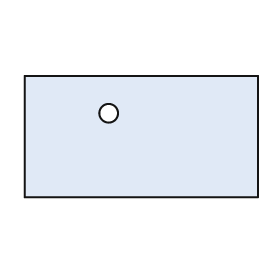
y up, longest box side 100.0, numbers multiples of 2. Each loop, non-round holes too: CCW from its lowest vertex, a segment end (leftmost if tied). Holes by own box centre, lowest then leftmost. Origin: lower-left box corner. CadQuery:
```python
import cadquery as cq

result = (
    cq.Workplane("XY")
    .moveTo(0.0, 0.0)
    .lineTo(100.0, 0.0)
    .lineTo(100.0, 52.0)
    .lineTo(0.0, 52.0)
    .close()
    .moveTo(36.0, 36.0)
    .circle(4.0)
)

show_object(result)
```